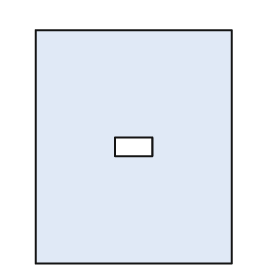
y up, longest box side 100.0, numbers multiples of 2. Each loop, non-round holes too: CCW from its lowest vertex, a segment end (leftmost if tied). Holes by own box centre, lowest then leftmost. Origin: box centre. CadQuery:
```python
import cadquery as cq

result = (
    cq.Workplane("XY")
    .moveTo(-42.0, -50.0)
    .lineTo(42.0, -50.0)
    .lineTo(42.0, 50.0)
    .lineTo(-42.0, 50.0)
    .close()
    .moveTo(-8.0, -4.0)
    .lineTo(8.0, -4.0)
    .lineTo(8.0, 4.0)
    .lineTo(-8.0, 4.0)
    .close()
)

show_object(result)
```